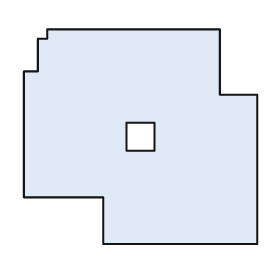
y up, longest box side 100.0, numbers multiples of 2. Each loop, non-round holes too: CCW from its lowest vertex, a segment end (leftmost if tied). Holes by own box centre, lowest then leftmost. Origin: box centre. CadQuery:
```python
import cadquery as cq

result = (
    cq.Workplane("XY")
    .moveTo(-16.0, -46.0)
    .lineTo(50.0, -46.0)
    .lineTo(50.0, 18.0)
    .lineTo(34.0, 18.0)
    .lineTo(34.0, 46.0)
    .lineTo(-40.0, 46.0)
    .lineTo(-40.0, 42.0)
    .lineTo(-44.0, 42.0)
    .lineTo(-44.0, 28.0)
    .lineTo(-50.0, 28.0)
    .lineTo(-50.0, -26.0)
    .lineTo(-16.0, -26.0)
    .close()
    .moveTo(-6.0, -6.0)
    .lineTo(6.0, -6.0)
    .lineTo(6.0, 6.0)
    .lineTo(-6.0, 6.0)
    .close()
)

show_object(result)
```